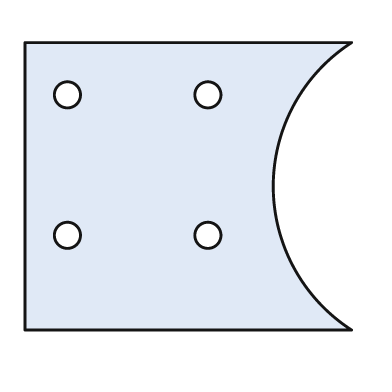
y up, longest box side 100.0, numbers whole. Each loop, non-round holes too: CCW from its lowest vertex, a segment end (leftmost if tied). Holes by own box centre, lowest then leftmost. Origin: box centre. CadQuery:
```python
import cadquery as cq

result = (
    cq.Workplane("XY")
    .moveTo(-50.0, -44.0)
    .lineTo(50.0, -44.0)
    .threePointArc((26.0, 0.0), (50.0, 44.0))
    .lineTo(-50.0, 44.0)
    .close()
    .moveTo(-37.0, -15.0)
    .circle(4.0)
    .moveTo(6.0, -15.0)
    .circle(4.0)
    .moveTo(-37.0, 28.0)
    .circle(4.0)
    .moveTo(6.0, 28.0)
    .circle(4.0)
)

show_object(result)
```